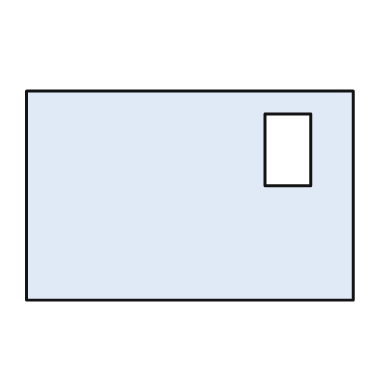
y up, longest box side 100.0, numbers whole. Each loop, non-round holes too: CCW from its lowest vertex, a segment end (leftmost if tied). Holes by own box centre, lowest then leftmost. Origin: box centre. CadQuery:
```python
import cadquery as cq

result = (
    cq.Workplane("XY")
    .moveTo(-50.0, -32.0)
    .lineTo(50.0, -32.0)
    .lineTo(50.0, 32.0)
    .lineTo(-50.0, 32.0)
    .close()
    .moveTo(23.0, 3.0)
    .lineTo(37.0, 3.0)
    .lineTo(37.0, 25.0)
    .lineTo(23.0, 25.0)
    .close()
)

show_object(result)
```